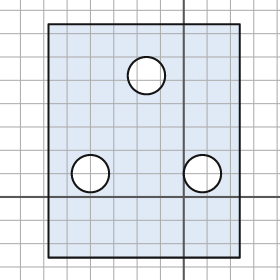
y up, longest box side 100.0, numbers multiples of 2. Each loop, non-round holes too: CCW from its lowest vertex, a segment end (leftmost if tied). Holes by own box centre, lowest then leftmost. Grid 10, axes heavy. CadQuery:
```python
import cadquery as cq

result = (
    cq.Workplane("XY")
    .moveTo(-58.0, -26.0)
    .lineTo(24.0, -26.0)
    .lineTo(24.0, 74.0)
    .lineTo(-58.0, 74.0)
    .close()
    .moveTo(-40.0, 10.0)
    .circle(8.0)
    .moveTo(8.0, 10.0)
    .circle(8.0)
    .moveTo(-16.0, 52.0)
    .circle(8.0)
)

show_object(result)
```